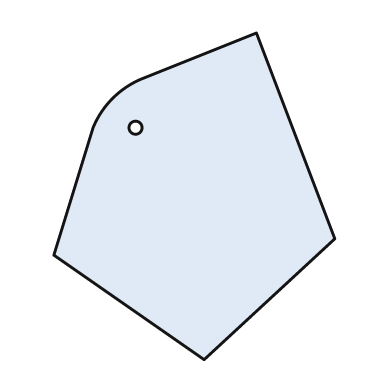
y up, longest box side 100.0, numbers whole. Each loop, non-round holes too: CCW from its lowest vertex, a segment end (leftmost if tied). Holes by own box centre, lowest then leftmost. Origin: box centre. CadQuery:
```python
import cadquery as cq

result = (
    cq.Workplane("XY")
    .moveTo(3.0, -50.0)
    .lineTo(43.0, -13.0)
    .lineTo(19.0, 50.0)
    .lineTo(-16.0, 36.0)
    .threePointArc((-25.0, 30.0), (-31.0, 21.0))
    .lineTo(-43.0, -18.0)
    .close()
    .moveTo(-18.0, 21.0)
    .circle(2.0)
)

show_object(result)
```